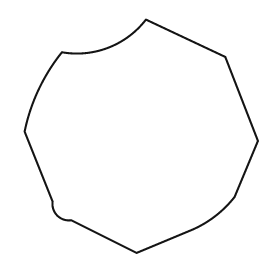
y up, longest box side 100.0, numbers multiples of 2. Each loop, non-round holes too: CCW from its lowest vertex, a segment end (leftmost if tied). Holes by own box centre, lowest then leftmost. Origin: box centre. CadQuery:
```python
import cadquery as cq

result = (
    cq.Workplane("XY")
    .moveTo(-2.0, -50.0)
    .lineTo(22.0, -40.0)
    .threePointArc((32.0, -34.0), (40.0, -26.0))
    .lineTo(50.0, -2.0)
    .lineTo(36.0, 34.0)
    .lineTo(2.0, 50.0)
    .threePointArc((-14.0, 38.0), (-34.0, 36.0))
    .threePointArc((-44.0, 20.0), (-50.0, 2.0))
    .lineTo(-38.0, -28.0)
    .threePointArc((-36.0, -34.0), (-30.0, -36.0))
    .close()
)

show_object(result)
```